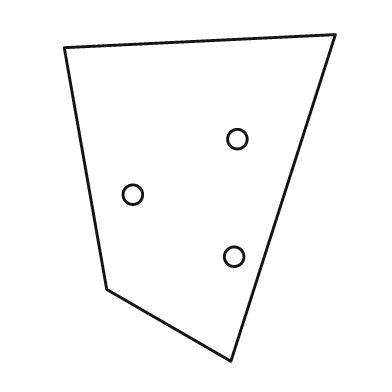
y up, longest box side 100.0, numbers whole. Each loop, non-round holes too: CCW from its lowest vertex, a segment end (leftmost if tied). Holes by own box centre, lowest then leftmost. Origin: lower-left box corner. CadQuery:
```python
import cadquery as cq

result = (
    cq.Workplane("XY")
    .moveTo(51.0, 0.0)
    .lineTo(83.0, 100.0)
    .lineTo(0.0, 96.0)
    .lineTo(13.0, 22.0)
    .close()
    .moveTo(52.0, 32.0)
    .circle(3.0)
    .moveTo(21.0, 51.0)
    .circle(3.0)
    .moveTo(53.0, 68.0)
    .circle(3.0)
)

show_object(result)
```